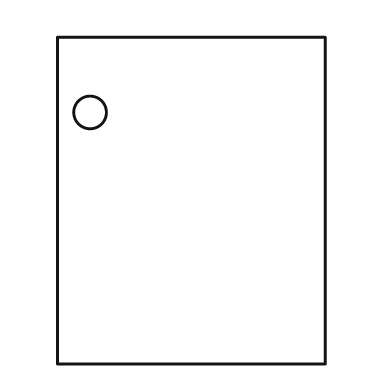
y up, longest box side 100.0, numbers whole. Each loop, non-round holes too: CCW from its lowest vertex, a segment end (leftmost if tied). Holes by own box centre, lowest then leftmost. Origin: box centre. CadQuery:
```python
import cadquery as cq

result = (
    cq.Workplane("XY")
    .moveTo(-41.0, -50.0)
    .lineTo(41.0, -50.0)
    .lineTo(41.0, 50.0)
    .lineTo(-41.0, 50.0)
    .close()
    .moveTo(-31.0, 27.0)
    .circle(5.0)
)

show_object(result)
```